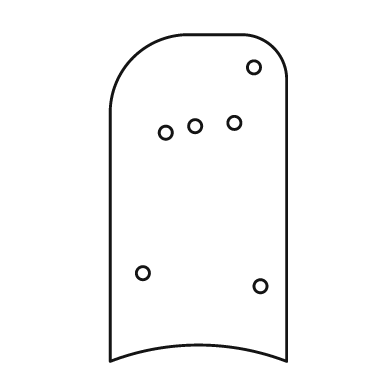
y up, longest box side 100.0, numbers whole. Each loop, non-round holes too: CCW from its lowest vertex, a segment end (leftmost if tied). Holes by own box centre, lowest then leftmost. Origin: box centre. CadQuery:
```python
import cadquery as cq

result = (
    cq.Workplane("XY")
    .moveTo(-27.0, -50.0)
    .threePointArc((0.0, -45.0), (27.0, -50.0))
    .lineTo(27.0, 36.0)
    .threePointArc((23.0, 46.0), (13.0, 50.0))
    .lineTo(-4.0, 50.0)
    .threePointArc((-20.0, 43.0), (-27.0, 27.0))
    .close()
    .moveTo(19.0, -27.0)
    .circle(2.0)
    .moveTo(-17.0, -23.0)
    .circle(2.0)
    .moveTo(-10.0, 20.0)
    .circle(2.0)
    .moveTo(-1.0, 22.0)
    .circle(2.0)
    .moveTo(11.0, 23.0)
    .circle(2.0)
    .moveTo(17.0, 40.0)
    .circle(2.0)
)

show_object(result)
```